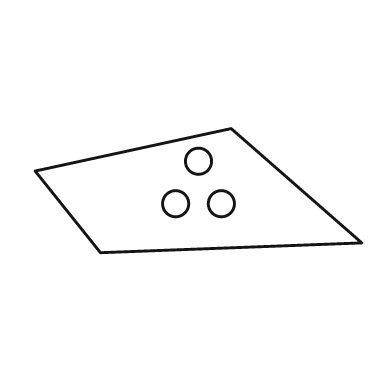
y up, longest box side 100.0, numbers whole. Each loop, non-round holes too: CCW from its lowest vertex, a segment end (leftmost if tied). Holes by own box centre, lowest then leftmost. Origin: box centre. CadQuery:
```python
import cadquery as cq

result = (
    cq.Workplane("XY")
    .moveTo(-30.0, -19.0)
    .lineTo(50.0, -16.0)
    .lineTo(10.0, 19.0)
    .lineTo(-50.0, 6.0)
    .close()
    .moveTo(-7.0, -4.0)
    .circle(4.0)
    .moveTo(7.0, -4.0)
    .circle(4.0)
    .moveTo(0.0, 9.0)
    .circle(4.0)
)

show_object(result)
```